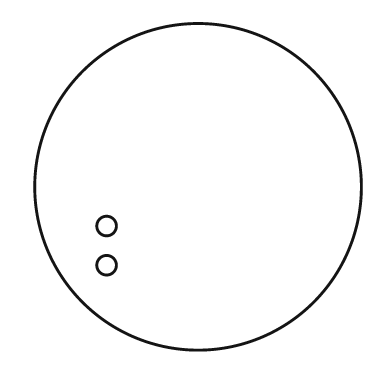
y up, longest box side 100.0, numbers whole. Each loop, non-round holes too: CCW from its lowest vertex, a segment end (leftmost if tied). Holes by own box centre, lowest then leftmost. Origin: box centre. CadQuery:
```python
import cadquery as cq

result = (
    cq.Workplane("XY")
    .moveTo(0.0, 0.0)
    .circle(50.0)
    .moveTo(-28.0, -24.0)
    .circle(3.0)
    .moveTo(-28.0, -12.0)
    .circle(3.0)
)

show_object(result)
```